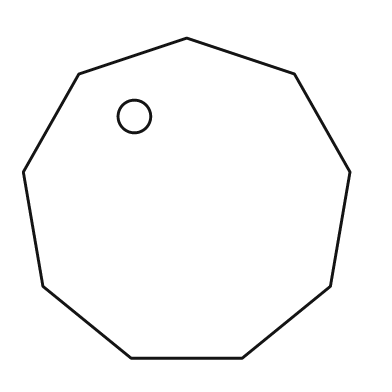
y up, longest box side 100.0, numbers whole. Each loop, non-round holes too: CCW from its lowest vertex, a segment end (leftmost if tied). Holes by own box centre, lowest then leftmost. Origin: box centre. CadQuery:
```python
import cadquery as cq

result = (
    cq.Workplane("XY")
    .moveTo(-17.0, -49.0)
    .lineTo(17.0, -49.0)
    .lineTo(44.0, -27.0)
    .lineTo(50.0, 8.0)
    .lineTo(33.0, 38.0)
    .lineTo(0.0, 49.0)
    .lineTo(-33.0, 38.0)
    .lineTo(-50.0, 8.0)
    .lineTo(-44.0, -27.0)
    .close()
    .moveTo(-16.0, 25.0)
    .circle(5.0)
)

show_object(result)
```